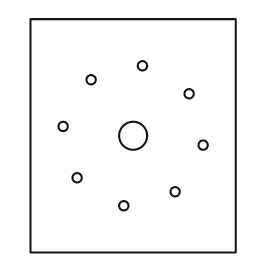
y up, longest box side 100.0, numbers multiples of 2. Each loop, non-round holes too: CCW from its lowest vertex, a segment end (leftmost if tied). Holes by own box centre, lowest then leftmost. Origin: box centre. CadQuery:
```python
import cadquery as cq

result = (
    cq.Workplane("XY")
    .moveTo(-44.0, -50.0)
    .lineTo(44.0, -50.0)
    .lineTo(44.0, 50.0)
    .lineTo(-44.0, 50.0)
    .close()
    .moveTo(-4.0, -30.0)
    .circle(2.0)
    .moveTo(18.0, -24.0)
    .circle(2.0)
    .moveTo(-24.0, -18.0)
    .circle(2.0)
    .moveTo(30.0, -4.0)
    .circle(2.0)
    .moveTo(0.0, 0.0)
    .circle(6.0)
    .moveTo(-30.0, 4.0)
    .circle(2.0)
    .moveTo(24.0, 18.0)
    .circle(2.0)
    .moveTo(-18.0, 24.0)
    .circle(2.0)
    .moveTo(4.0, 30.0)
    .circle(2.0)
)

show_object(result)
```